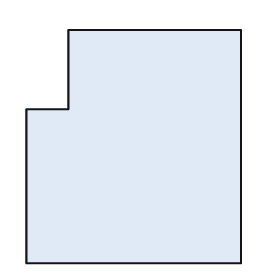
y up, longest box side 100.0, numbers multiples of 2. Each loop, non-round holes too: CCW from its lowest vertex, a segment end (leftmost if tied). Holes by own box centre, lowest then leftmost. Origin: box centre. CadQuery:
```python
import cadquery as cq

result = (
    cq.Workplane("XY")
    .moveTo(-46.0, -50.0)
    .lineTo(46.0, -50.0)
    .lineTo(46.0, 50.0)
    .lineTo(-28.0, 50.0)
    .lineTo(-28.0, 16.0)
    .lineTo(-46.0, 16.0)
    .close()
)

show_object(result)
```